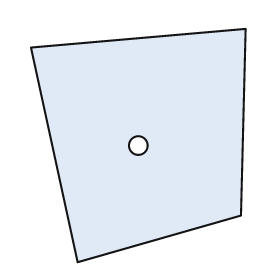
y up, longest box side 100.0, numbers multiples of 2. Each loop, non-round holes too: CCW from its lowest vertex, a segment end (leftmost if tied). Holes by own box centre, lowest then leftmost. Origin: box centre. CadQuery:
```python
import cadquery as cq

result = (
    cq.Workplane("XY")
    .moveTo(-26.0, -50.0)
    .lineTo(44.0, -30.0)
    .lineTo(46.0, 50.0)
    .lineTo(-46.0, 42.0)
    .close()
    .moveTo(0.0, 0.0)
    .circle(4.0)
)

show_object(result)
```